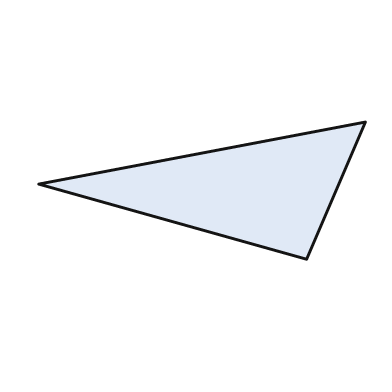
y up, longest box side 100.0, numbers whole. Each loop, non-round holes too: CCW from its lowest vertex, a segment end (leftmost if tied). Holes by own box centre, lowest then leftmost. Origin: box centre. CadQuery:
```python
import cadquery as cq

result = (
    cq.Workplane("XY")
    .moveTo(32.0, -21.0)
    .lineTo(50.0, 21.0)
    .lineTo(-50.0, 2.0)
    .close()
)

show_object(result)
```